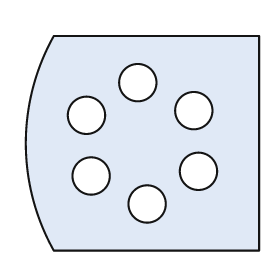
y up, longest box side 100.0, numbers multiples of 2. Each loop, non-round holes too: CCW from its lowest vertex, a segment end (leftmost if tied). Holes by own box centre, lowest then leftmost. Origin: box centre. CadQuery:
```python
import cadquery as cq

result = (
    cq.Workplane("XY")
    .moveTo(-38.0, -46.0)
    .lineTo(50.0, -46.0)
    .lineTo(50.0, 46.0)
    .lineTo(-38.0, 46.0)
    .threePointArc((-50.0, 0.0), (-38.0, -46.0))
    .close()
    .moveTo(2.0, -26.0)
    .circle(8.0)
    .moveTo(-22.0, -14.0)
    .circle(8.0)
    .moveTo(24.0, -12.0)
    .circle(8.0)
    .moveTo(-24.0, 12.0)
    .circle(8.0)
    .moveTo(22.0, 14.0)
    .circle(8.0)
    .moveTo(-2.0, 26.0)
    .circle(8.0)
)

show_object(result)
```